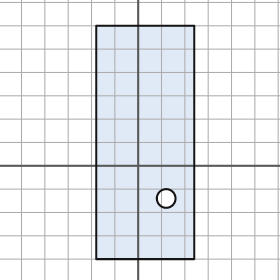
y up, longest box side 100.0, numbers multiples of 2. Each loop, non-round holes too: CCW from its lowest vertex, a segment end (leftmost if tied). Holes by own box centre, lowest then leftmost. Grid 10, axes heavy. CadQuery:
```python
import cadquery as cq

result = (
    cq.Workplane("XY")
    .moveTo(-18.0, -40.0)
    .lineTo(24.0, -40.0)
    .lineTo(24.0, 60.0)
    .lineTo(-18.0, 60.0)
    .close()
    .moveTo(12.0, -14.0)
    .circle(4.0)
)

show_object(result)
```